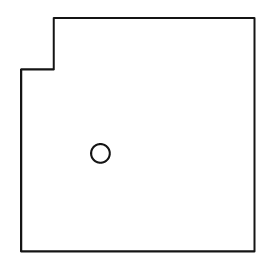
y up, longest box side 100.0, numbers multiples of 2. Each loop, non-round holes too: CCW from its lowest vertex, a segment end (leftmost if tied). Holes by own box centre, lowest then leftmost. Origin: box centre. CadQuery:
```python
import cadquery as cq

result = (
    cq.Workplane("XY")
    .moveTo(-50.0, -50.0)
    .lineTo(50.0, -50.0)
    .lineTo(50.0, 50.0)
    .lineTo(-36.0, 50.0)
    .lineTo(-36.0, 28.0)
    .lineTo(-50.0, 28.0)
    .close()
    .moveTo(-16.0, -8.0)
    .circle(4.0)
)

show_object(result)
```